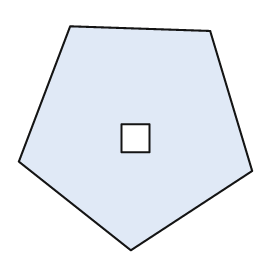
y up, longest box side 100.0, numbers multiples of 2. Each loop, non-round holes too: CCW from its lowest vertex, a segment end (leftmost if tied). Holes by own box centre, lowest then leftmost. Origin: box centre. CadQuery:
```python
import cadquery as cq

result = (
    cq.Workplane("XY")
    .moveTo(-2.0, -48.0)
    .lineTo(50.0, -14.0)
    .lineTo(32.0, 46.0)
    .lineTo(-28.0, 48.0)
    .lineTo(-50.0, -10.0)
    .close()
    .moveTo(-6.0, -6.0)
    .lineTo(6.0, -6.0)
    .lineTo(6.0, 6.0)
    .lineTo(-6.0, 6.0)
    .close()
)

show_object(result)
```